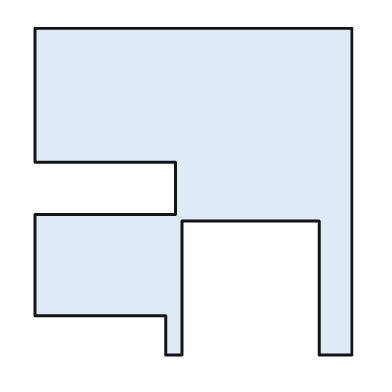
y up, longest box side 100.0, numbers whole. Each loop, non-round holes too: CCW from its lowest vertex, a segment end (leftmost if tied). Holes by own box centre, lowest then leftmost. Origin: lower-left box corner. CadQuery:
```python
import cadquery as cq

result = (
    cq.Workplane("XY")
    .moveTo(40.0, 0.0)
    .lineTo(45.0, 0.0)
    .lineTo(45.0, 41.0)
    .lineTo(87.0, 41.0)
    .lineTo(87.0, 0.0)
    .lineTo(97.0, 0.0)
    .lineTo(97.0, 100.0)
    .lineTo(0.0, 100.0)
    .lineTo(0.0, 59.0)
    .lineTo(43.0, 59.0)
    .lineTo(43.0, 43.0)
    .lineTo(0.0, 43.0)
    .lineTo(0.0, 12.0)
    .lineTo(40.0, 12.0)
    .close()
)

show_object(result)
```